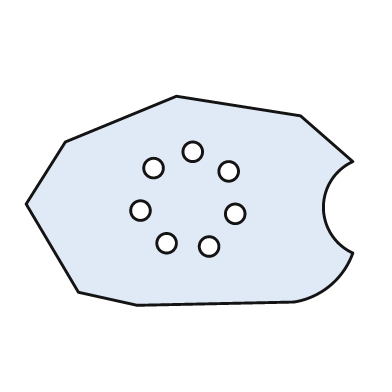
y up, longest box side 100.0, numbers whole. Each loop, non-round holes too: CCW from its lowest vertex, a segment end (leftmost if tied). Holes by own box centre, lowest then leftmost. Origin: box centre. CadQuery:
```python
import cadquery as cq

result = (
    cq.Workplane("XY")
    .moveTo(-16.0, -32.0)
    .lineTo(32.0, -31.0)
    .threePointArc((43.0, -26.0), (50.0, -16.0))
    .threePointArc((41.0, -2.0), (50.0, 12.0))
    .lineTo(34.0, 26.0)
    .lineTo(-4.0, 32.0)
    .lineTo(-38.0, 18.0)
    .lineTo(-50.0, -1.0)
    .lineTo(-34.0, -28.0)
    .close()
    .moveTo(6.0, -14.0)
    .circle(3.0)
    .moveTo(-7.0, -13.0)
    .circle(3.0)
    .moveTo(14.0, -4.0)
    .circle(3.0)
    .moveTo(-15.0, -3.0)
    .circle(3.0)
    .moveTo(12.0, 9.0)
    .circle(3.0)
    .moveTo(-11.0, 10.0)
    .circle(3.0)
    .moveTo(1.0, 15.0)
    .circle(3.0)
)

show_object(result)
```